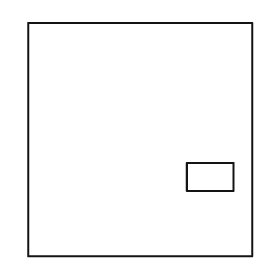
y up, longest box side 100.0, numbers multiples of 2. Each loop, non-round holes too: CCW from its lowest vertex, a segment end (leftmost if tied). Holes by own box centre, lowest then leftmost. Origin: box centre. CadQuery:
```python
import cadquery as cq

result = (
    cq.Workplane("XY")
    .moveTo(-48.0, -50.0)
    .lineTo(48.0, -50.0)
    .lineTo(48.0, 50.0)
    .lineTo(-48.0, 50.0)
    .close()
    .moveTo(20.0, -22.0)
    .lineTo(40.0, -22.0)
    .lineTo(40.0, -10.0)
    .lineTo(20.0, -10.0)
    .close()
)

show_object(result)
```